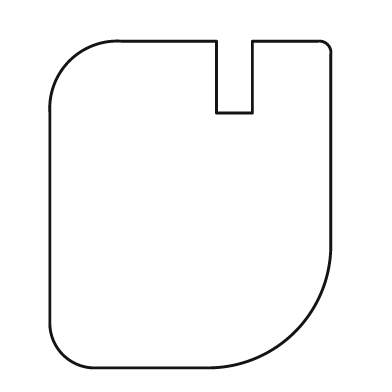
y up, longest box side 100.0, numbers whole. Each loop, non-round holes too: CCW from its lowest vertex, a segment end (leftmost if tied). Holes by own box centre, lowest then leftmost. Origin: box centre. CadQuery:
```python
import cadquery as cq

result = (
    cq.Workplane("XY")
    .moveTo(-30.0, -50.0)
    .lineTo(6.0, -50.0)
    .threePointArc((32.0, -39.0), (43.0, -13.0))
    .lineTo(43.0, 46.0)
    .threePointArc((42.0, 49.0), (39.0, 50.0))
    .lineTo(19.0, 50.0)
    .lineTo(19.0, 28.0)
    .lineTo(8.0, 28.0)
    .lineTo(8.0, 50.0)
    .lineTo(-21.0, 50.0)
    .threePointArc((-37.0, 44.0), (-43.0, 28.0))
    .lineTo(-43.0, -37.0)
    .threePointArc((-39.0, -46.0), (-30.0, -50.0))
    .close()
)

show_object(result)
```